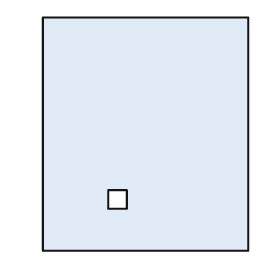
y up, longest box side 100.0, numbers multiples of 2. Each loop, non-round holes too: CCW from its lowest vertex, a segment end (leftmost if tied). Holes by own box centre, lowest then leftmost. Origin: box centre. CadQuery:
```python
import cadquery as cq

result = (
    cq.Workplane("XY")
    .moveTo(-44.0, -50.0)
    .lineTo(44.0, -50.0)
    .lineTo(44.0, 50.0)
    .lineTo(-44.0, 50.0)
    .close()
    .moveTo(-16.0, -32.0)
    .lineTo(-8.0, -32.0)
    .lineTo(-8.0, -24.0)
    .lineTo(-16.0, -24.0)
    .close()
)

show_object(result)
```